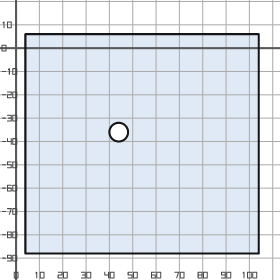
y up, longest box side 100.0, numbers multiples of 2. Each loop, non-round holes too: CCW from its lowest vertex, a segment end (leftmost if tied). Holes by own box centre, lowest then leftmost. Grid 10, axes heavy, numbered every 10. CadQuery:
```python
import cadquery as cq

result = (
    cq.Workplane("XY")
    .moveTo(4.0, -88.0)
    .lineTo(104.0, -88.0)
    .lineTo(104.0, 6.0)
    .lineTo(4.0, 6.0)
    .close()
    .moveTo(44.0, -36.0)
    .circle(4.0)
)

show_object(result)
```